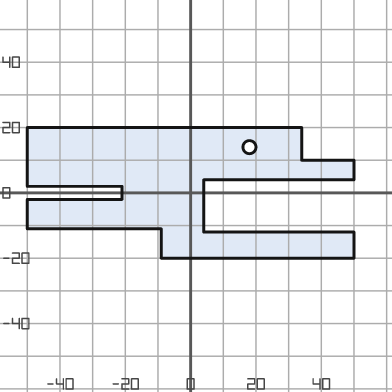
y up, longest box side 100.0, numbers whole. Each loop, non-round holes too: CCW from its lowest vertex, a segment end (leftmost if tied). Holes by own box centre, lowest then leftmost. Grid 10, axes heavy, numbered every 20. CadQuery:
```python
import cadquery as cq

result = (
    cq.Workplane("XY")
    .moveTo(-9.0, -20.0)
    .lineTo(50.0, -20.0)
    .lineTo(50.0, -12.0)
    .lineTo(4.0, -12.0)
    .lineTo(4.0, 4.0)
    .lineTo(50.0, 4.0)
    .lineTo(50.0, 10.0)
    .lineTo(34.0, 10.0)
    .lineTo(34.0, 20.0)
    .lineTo(-50.0, 20.0)
    .lineTo(-50.0, 2.0)
    .lineTo(-21.0, 2.0)
    .lineTo(-21.0, -2.0)
    .lineTo(-50.0, -2.0)
    .lineTo(-50.0, -11.0)
    .lineTo(-9.0, -11.0)
    .close()
    .moveTo(18.0, 14.0)
    .circle(2.0)
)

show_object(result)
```